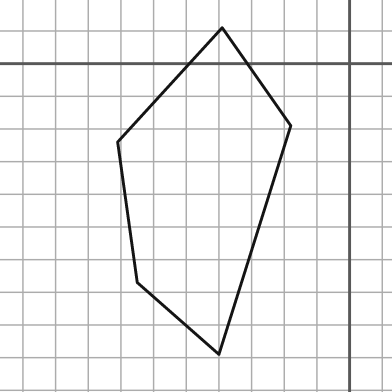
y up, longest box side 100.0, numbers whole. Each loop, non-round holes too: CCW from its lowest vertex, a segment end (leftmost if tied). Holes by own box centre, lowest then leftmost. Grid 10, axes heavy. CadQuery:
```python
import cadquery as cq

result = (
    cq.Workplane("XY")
    .moveTo(-40.0, -89.0)
    .lineTo(-18.0, -19.0)
    .lineTo(-39.0, 11.0)
    .lineTo(-71.0, -24.0)
    .lineTo(-65.0, -67.0)
    .close()
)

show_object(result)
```